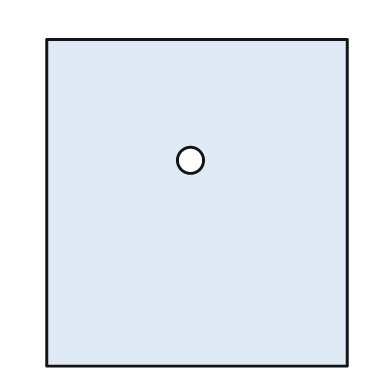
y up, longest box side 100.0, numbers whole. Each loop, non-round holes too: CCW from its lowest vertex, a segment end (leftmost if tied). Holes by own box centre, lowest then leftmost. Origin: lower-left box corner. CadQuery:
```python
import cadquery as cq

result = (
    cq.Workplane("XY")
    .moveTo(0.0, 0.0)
    .lineTo(92.0, 0.0)
    .lineTo(92.0, 100.0)
    .lineTo(0.0, 100.0)
    .close()
    .moveTo(44.0, 63.0)
    .circle(4.0)
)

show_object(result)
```